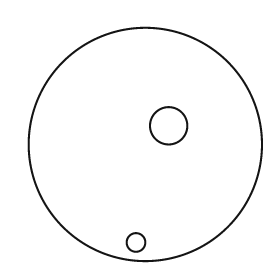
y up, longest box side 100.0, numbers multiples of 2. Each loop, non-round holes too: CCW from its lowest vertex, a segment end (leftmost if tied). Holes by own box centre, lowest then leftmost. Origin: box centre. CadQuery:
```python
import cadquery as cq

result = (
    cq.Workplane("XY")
    .moveTo(0.0, 0.0)
    .circle(50.0)
    .moveTo(-4.0, -42.0)
    .circle(4.0)
    .moveTo(10.0, 8.0)
    .circle(8.0)
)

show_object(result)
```